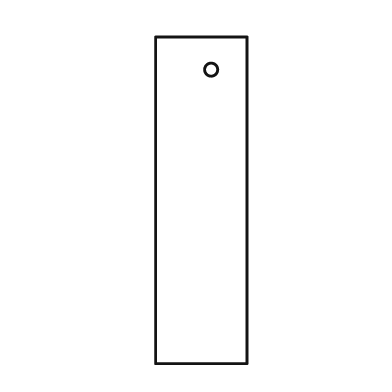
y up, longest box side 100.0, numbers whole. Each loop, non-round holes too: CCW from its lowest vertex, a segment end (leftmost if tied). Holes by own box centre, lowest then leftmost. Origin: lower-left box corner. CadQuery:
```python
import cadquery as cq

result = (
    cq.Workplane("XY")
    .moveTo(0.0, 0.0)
    .lineTo(28.0, 0.0)
    .lineTo(28.0, 100.0)
    .lineTo(0.0, 100.0)
    .close()
    .moveTo(17.0, 90.0)
    .circle(2.0)
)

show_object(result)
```